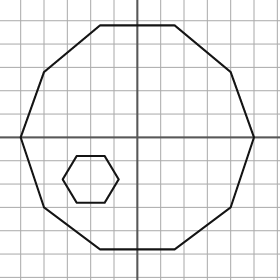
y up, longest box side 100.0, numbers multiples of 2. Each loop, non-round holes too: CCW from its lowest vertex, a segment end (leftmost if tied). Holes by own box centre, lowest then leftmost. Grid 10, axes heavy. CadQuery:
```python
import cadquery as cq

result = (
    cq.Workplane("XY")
    .moveTo(-16.0, -48.0)
    .lineTo(16.0, -48.0)
    .lineTo(40.0, -30.0)
    .lineTo(50.0, 0.0)
    .lineTo(40.0, 28.0)
    .lineTo(16.0, 48.0)
    .lineTo(-16.0, 48.0)
    .lineTo(-40.0, 28.0)
    .lineTo(-50.0, 0.0)
    .lineTo(-40.0, -30.0)
    .close()
    .moveTo(-26.0, -28.0)
    .lineTo(-14.0, -28.0)
    .lineTo(-8.0, -18.0)
    .lineTo(-14.0, -8.0)
    .lineTo(-26.0, -8.0)
    .lineTo(-32.0, -18.0)
    .close()
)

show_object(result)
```